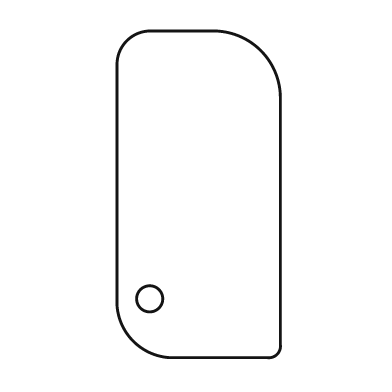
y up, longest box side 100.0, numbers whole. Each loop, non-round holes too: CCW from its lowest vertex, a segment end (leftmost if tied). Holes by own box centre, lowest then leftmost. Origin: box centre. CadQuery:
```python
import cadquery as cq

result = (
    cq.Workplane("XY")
    .moveTo(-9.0, -50.0)
    .lineTo(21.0, -50.0)
    .threePointArc((24.0, -49.0), (25.0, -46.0))
    .lineTo(25.0, 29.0)
    .threePointArc((19.0, 44.0), (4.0, 50.0))
    .lineTo(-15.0, 50.0)
    .threePointArc((-22.0, 47.0), (-25.0, 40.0))
    .lineTo(-25.0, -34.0)
    .threePointArc((-20.0, -45.0), (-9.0, -50.0))
    .close()
    .moveTo(-15.0, -32.0)
    .circle(4.0)
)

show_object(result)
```